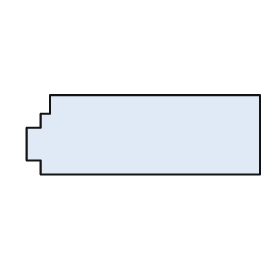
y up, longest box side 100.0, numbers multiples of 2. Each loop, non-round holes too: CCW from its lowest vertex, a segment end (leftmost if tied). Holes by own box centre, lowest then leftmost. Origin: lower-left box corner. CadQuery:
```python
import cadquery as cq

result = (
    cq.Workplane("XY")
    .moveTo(6.0, 0.0)
    .lineTo(100.0, 0.0)
    .lineTo(100.0, 34.0)
    .lineTo(10.0, 34.0)
    .lineTo(10.0, 26.0)
    .lineTo(6.0, 26.0)
    .lineTo(6.0, 20.0)
    .lineTo(0.0, 20.0)
    .lineTo(0.0, 6.0)
    .lineTo(6.0, 6.0)
    .close()
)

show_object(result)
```